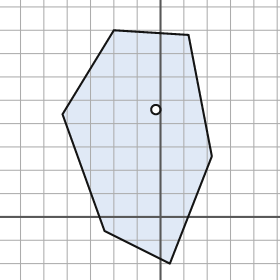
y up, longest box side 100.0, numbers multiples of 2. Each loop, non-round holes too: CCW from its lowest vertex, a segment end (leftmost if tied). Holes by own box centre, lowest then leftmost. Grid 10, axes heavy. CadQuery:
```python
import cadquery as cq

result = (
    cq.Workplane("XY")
    .moveTo(4.0, -20.0)
    .lineTo(22.0, 26.0)
    .lineTo(12.0, 78.0)
    .lineTo(-20.0, 80.0)
    .lineTo(-42.0, 44.0)
    .lineTo(-24.0, -6.0)
    .close()
    .moveTo(-2.0, 46.0)
    .circle(2.0)
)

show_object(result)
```